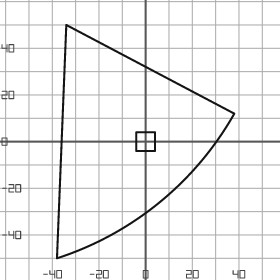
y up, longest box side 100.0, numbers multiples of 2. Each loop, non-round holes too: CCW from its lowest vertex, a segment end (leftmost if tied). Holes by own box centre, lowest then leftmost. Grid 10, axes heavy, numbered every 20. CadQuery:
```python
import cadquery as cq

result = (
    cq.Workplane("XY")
    .moveTo(-38.0, -50.0)
    .threePointArc((6.0, -26.0), (38.0, 12.0))
    .lineTo(-34.0, 50.0)
    .close()
    .moveTo(-4.0, -4.0)
    .lineTo(4.0, -4.0)
    .lineTo(4.0, 4.0)
    .lineTo(-4.0, 4.0)
    .close()
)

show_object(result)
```